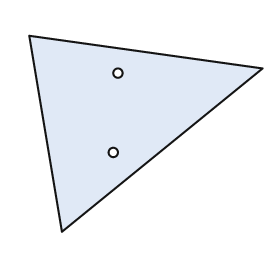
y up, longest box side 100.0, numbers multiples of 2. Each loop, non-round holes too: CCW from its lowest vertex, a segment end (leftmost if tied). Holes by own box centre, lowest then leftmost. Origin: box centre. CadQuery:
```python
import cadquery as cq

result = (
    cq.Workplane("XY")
    .moveTo(-36.0, -42.0)
    .lineTo(50.0, 28.0)
    .lineTo(-50.0, 42.0)
    .close()
    .moveTo(-14.0, -8.0)
    .circle(2.0)
    .moveTo(-12.0, 26.0)
    .circle(2.0)
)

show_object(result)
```